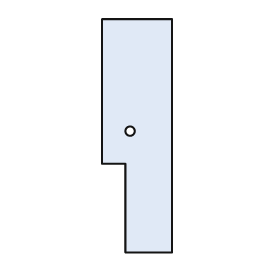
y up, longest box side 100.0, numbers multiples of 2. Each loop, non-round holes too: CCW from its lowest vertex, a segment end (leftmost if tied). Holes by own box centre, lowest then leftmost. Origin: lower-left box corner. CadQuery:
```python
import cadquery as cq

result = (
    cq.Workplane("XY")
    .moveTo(10.0, 0.0)
    .lineTo(30.0, 0.0)
    .lineTo(30.0, 100.0)
    .lineTo(0.0, 100.0)
    .lineTo(0.0, 38.0)
    .lineTo(10.0, 38.0)
    .close()
    .moveTo(12.0, 52.0)
    .circle(2.0)
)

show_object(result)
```